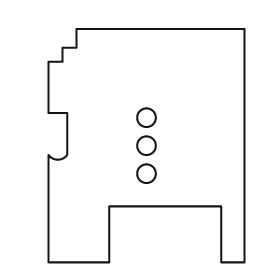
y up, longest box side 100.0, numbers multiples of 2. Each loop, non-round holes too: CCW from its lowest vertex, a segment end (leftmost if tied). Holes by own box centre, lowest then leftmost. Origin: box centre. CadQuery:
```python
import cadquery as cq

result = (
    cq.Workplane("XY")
    .moveTo(-42.0, -50.0)
    .lineTo(-16.0, -50.0)
    .lineTo(-16.0, -26.0)
    .lineTo(32.0, -26.0)
    .lineTo(32.0, -50.0)
    .lineTo(42.0, -50.0)
    .lineTo(42.0, 50.0)
    .lineTo(-30.0, 50.0)
    .lineTo(-30.0, 42.0)
    .lineTo(-36.0, 42.0)
    .lineTo(-36.0, 36.0)
    .lineTo(-42.0, 36.0)
    .lineTo(-42.0, 14.0)
    .lineTo(-34.0, 14.0)
    .lineTo(-34.0, -4.0)
    .threePointArc((-38.0, -6.0), (-42.0, -4.0))
    .close()
    .moveTo(0.0, -12.0)
    .circle(4.0)
    .moveTo(0.0, 0.0)
    .circle(4.0)
    .moveTo(0.0, 12.0)
    .circle(4.0)
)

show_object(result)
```